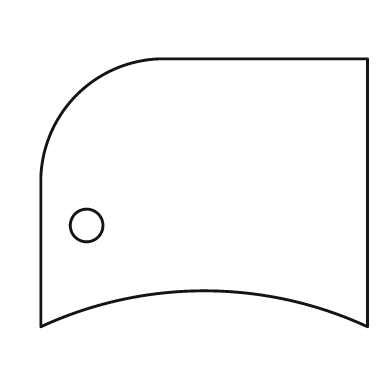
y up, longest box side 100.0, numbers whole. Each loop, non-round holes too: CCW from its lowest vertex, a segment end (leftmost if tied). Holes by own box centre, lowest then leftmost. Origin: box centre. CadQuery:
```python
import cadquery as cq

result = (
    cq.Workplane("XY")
    .moveTo(-50.0, -41.0)
    .threePointArc((0.0, -30.0), (50.0, -41.0))
    .lineTo(50.0, 41.0)
    .lineTo(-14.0, 41.0)
    .threePointArc((-39.0, 30.0), (-50.0, 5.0))
    .close()
    .moveTo(-36.0, -10.0)
    .circle(5.0)
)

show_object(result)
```